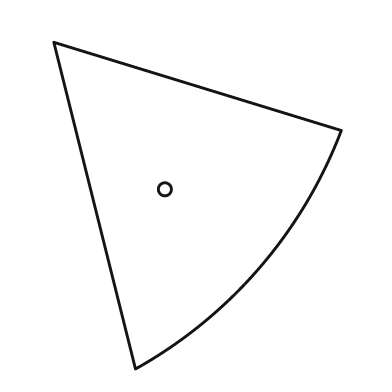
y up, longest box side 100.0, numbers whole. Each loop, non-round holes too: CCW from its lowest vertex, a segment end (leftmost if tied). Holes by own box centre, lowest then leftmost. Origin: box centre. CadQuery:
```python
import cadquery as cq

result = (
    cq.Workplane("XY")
    .moveTo(-19.0, -50.0)
    .threePointArc((19.0, -19.0), (44.0, 23.0))
    .lineTo(-44.0, 50.0)
    .close()
    .moveTo(-10.0, 5.0)
    .circle(2.0)
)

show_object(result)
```